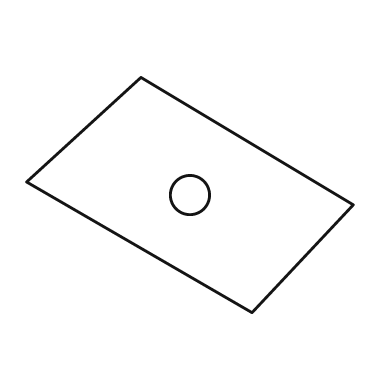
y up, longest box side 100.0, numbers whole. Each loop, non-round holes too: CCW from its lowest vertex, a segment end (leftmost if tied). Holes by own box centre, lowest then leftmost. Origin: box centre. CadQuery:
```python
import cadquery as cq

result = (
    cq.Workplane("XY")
    .moveTo(19.0, -36.0)
    .lineTo(50.0, -3.0)
    .lineTo(-15.0, 36.0)
    .lineTo(-50.0, 4.0)
    .close()
    .moveTo(0.0, 0.0)
    .circle(6.0)
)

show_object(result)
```